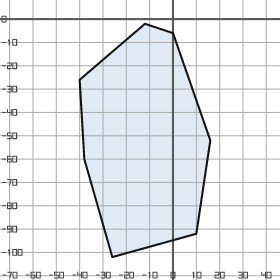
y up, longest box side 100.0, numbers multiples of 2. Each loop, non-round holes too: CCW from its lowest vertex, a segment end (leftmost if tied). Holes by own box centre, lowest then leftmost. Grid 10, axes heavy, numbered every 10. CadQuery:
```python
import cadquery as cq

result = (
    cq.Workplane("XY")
    .moveTo(-26.0, -102.0)
    .lineTo(10.0, -92.0)
    .lineTo(16.0, -52.0)
    .lineTo(0.0, -6.0)
    .lineTo(-12.0, -2.0)
    .lineTo(-40.0, -26.0)
    .lineTo(-38.0, -60.0)
    .close()
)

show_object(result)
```